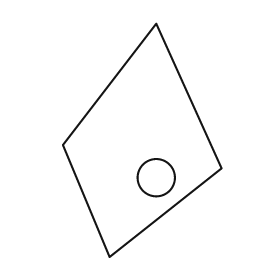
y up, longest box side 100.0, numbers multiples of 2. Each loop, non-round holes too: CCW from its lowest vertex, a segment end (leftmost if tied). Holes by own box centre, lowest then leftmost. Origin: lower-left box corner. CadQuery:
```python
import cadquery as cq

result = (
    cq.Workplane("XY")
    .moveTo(20.0, 0.0)
    .lineTo(68.0, 38.0)
    .lineTo(40.0, 100.0)
    .lineTo(0.0, 48.0)
    .close()
    .moveTo(40.0, 34.0)
    .circle(8.0)
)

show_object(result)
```